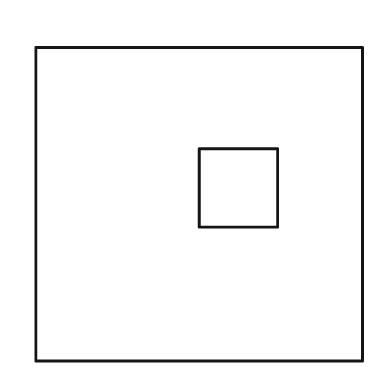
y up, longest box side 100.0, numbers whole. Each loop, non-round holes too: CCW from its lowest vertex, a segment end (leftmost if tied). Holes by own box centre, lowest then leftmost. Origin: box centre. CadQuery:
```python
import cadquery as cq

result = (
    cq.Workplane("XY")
    .moveTo(-50.0, -48.0)
    .lineTo(50.0, -48.0)
    .lineTo(50.0, 48.0)
    .lineTo(-50.0, 48.0)
    .close()
    .moveTo(0.0, -7.0)
    .lineTo(24.0, -7.0)
    .lineTo(24.0, 17.0)
    .lineTo(0.0, 17.0)
    .close()
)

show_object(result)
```